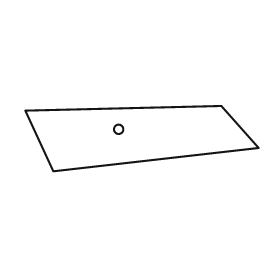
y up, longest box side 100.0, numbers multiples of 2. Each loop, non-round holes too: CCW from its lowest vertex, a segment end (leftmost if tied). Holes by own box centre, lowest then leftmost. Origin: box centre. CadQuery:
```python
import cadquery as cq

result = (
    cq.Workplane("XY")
    .moveTo(-38.0, -14.0)
    .lineTo(50.0, -4.0)
    .lineTo(34.0, 14.0)
    .lineTo(-50.0, 12.0)
    .close()
    .moveTo(-10.0, 4.0)
    .circle(2.0)
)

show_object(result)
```